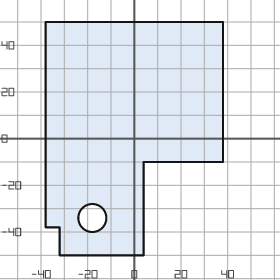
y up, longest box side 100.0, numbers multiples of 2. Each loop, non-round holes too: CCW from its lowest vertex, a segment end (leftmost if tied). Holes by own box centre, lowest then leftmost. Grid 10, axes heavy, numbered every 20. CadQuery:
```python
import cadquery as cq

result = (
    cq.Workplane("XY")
    .moveTo(-32.0, -50.0)
    .lineTo(4.0, -50.0)
    .lineTo(4.0, -10.0)
    .lineTo(38.0, -10.0)
    .lineTo(38.0, 50.0)
    .lineTo(-38.0, 50.0)
    .lineTo(-38.0, -38.0)
    .lineTo(-32.0, -38.0)
    .close()
    .moveTo(-18.0, -34.0)
    .circle(6.0)
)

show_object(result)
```